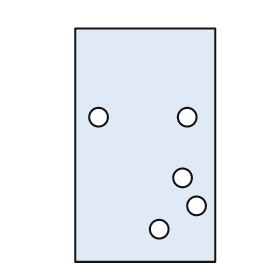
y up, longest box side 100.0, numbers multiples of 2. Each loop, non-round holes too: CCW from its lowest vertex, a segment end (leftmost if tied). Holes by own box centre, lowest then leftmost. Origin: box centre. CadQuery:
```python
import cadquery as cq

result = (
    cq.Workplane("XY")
    .moveTo(-30.0, -50.0)
    .lineTo(30.0, -50.0)
    .lineTo(30.0, 50.0)
    .lineTo(-30.0, 50.0)
    .close()
    .moveTo(6.0, -36.0)
    .circle(4.0)
    .moveTo(22.0, -26.0)
    .circle(4.0)
    .moveTo(16.0, -14.0)
    .circle(4.0)
    .moveTo(-20.0, 12.0)
    .circle(4.0)
    .moveTo(18.0, 12.0)
    .circle(4.0)
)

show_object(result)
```